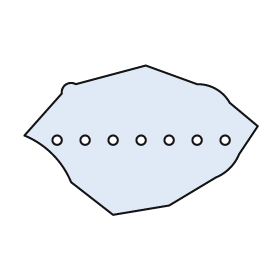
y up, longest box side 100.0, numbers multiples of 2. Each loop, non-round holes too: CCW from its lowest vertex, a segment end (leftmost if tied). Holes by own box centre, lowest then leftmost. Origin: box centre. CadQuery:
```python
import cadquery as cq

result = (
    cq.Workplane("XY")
    .moveTo(-12.0, -32.0)
    .lineTo(12.0, -28.0)
    .lineTo(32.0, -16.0)
    .threePointArc((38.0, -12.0), (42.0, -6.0))
    .lineTo(50.0, 6.0)
    .lineTo(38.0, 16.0)
    .threePointArc((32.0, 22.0), (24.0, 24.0))
    .lineTo(2.0, 32.0)
    .lineTo(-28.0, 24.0)
    .threePointArc((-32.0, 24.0), (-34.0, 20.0))
    .lineTo(-50.0, 2.0)
    .threePointArc((-38.0, -6.0), (-30.0, -18.0))
    .close()
    .moveTo(-36.0, 0.0)
    .circle(2.0)
    .moveTo(-24.0, 0.0)
    .circle(2.0)
    .moveTo(-12.0, 0.0)
    .circle(2.0)
    .moveTo(0.0, 0.0)
    .circle(2.0)
    .moveTo(12.0, 0.0)
    .circle(2.0)
    .moveTo(24.0, 0.0)
    .circle(2.0)
    .moveTo(36.0, 0.0)
    .circle(2.0)
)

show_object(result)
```